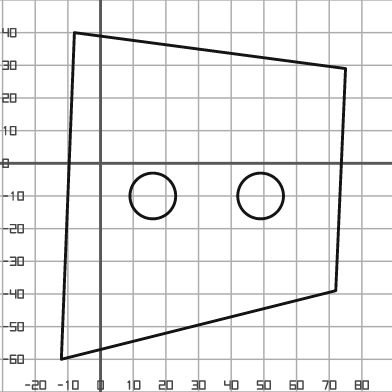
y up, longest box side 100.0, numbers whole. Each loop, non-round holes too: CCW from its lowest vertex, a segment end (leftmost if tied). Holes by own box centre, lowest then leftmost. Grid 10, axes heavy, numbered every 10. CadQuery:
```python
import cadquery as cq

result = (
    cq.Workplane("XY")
    .moveTo(-12.0, -60.0)
    .lineTo(72.0, -39.0)
    .lineTo(75.0, 29.0)
    .lineTo(-8.0, 40.0)
    .close()
    .moveTo(16.0, -10.0)
    .circle(7.0)
    .moveTo(49.0, -10.0)
    .circle(7.0)
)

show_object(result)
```